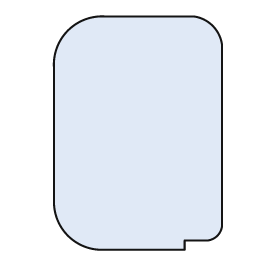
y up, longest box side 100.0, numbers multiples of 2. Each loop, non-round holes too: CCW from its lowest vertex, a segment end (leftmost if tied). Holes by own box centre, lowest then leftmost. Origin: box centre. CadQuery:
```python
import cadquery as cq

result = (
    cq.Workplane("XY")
    .moveTo(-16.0, -50.0)
    .lineTo(20.0, -50.0)
    .lineTo(20.0, -46.0)
    .lineTo(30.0, -46.0)
    .threePointArc((34.0, -44.0), (36.0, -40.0))
    .lineTo(36.0, 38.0)
    .threePointArc((32.0, 46.0), (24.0, 50.0))
    .lineTo(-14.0, 50.0)
    .threePointArc((-30.0, 44.0), (-36.0, 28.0))
    .lineTo(-36.0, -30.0)
    .threePointArc((-30.0, -44.0), (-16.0, -50.0))
    .close()
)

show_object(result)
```